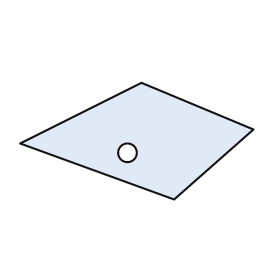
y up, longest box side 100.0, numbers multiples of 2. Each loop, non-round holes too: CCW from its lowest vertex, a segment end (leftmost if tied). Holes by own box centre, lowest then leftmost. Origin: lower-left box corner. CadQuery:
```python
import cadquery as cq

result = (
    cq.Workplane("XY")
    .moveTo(66.0, 0.0)
    .lineTo(100.0, 30.0)
    .lineTo(52.0, 50.0)
    .lineTo(0.0, 24.0)
    .close()
    .moveTo(46.0, 20.0)
    .circle(4.0)
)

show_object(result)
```